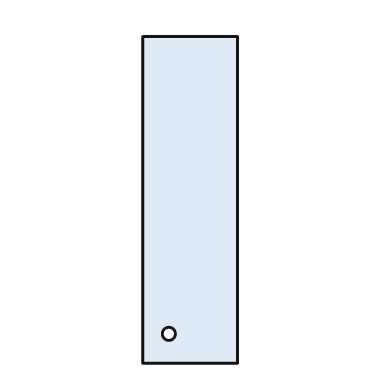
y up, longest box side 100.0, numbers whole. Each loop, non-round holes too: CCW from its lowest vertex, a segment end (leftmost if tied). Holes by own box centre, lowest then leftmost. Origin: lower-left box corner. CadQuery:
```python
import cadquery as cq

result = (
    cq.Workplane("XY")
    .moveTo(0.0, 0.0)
    .lineTo(29.0, 0.0)
    .lineTo(29.0, 100.0)
    .lineTo(0.0, 100.0)
    .close()
    .moveTo(8.0, 9.0)
    .circle(2.0)
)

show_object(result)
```